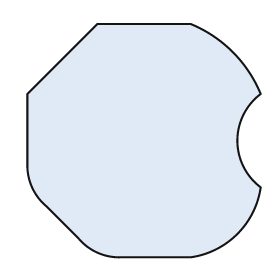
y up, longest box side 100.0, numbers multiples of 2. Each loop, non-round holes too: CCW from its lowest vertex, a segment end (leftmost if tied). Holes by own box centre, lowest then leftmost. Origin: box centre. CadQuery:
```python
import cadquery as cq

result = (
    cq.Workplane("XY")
    .moveTo(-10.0, -50.0)
    .lineTo(20.0, -50.0)
    .threePointArc((40.0, -40.0), (50.0, -20.0))
    .threePointArc((40.0, 0.0), (50.0, 20.0))
    .threePointArc((38.0, 38.0), (20.0, 50.0))
    .lineTo(-20.0, 50.0)
    .lineTo(-50.0, 20.0)
    .lineTo(-50.0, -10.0)
    .threePointArc((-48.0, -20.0), (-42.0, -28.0))
    .lineTo(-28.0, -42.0)
    .threePointArc((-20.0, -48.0), (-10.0, -50.0))
    .close()
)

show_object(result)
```